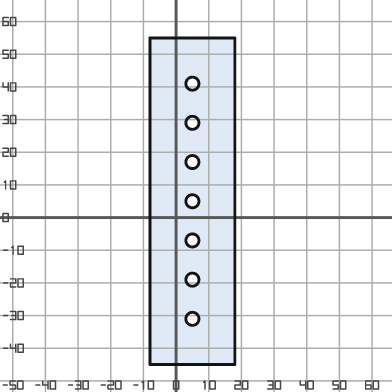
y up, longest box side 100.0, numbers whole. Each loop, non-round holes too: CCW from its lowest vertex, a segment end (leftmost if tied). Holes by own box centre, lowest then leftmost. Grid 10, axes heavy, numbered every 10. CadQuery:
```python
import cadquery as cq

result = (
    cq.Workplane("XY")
    .moveTo(-8.0, -45.0)
    .lineTo(18.0, -45.0)
    .lineTo(18.0, 55.0)
    .lineTo(-8.0, 55.0)
    .close()
    .moveTo(5.0, -31.0)
    .circle(2.0)
    .moveTo(5.0, -19.0)
    .circle(2.0)
    .moveTo(5.0, -7.0)
    .circle(2.0)
    .moveTo(5.0, 5.0)
    .circle(2.0)
    .moveTo(5.0, 17.0)
    .circle(2.0)
    .moveTo(5.0, 29.0)
    .circle(2.0)
    .moveTo(5.0, 41.0)
    .circle(2.0)
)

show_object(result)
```